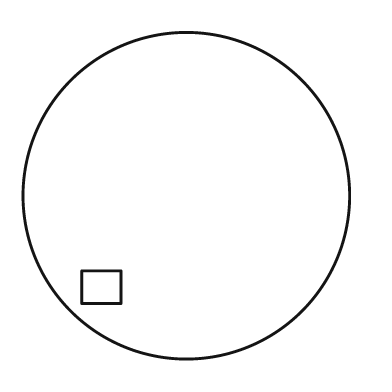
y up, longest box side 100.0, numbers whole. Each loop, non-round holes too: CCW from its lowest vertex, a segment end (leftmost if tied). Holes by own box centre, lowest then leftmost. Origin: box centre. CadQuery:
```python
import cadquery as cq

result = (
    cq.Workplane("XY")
    .moveTo(0.0, 0.0)
    .circle(50.0)
    .moveTo(-32.0, -33.0)
    .lineTo(-20.0, -33.0)
    .lineTo(-20.0, -23.0)
    .lineTo(-32.0, -23.0)
    .close()
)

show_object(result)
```